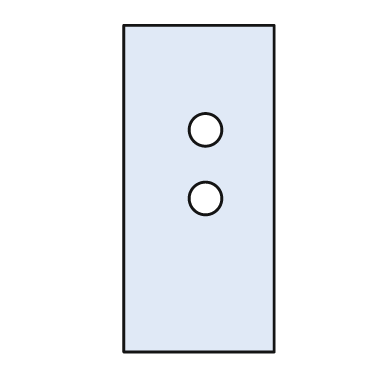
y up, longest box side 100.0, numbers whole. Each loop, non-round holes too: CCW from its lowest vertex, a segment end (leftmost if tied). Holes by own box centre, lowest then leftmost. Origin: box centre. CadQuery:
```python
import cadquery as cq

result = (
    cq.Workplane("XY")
    .moveTo(-23.0, -50.0)
    .lineTo(23.0, -50.0)
    .lineTo(23.0, 50.0)
    .lineTo(-23.0, 50.0)
    .close()
    .moveTo(2.0, -3.0)
    .circle(5.0)
    .moveTo(2.0, 18.0)
    .circle(5.0)
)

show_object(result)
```